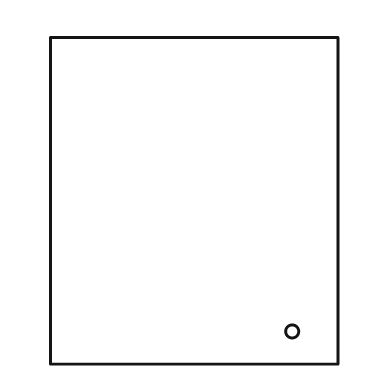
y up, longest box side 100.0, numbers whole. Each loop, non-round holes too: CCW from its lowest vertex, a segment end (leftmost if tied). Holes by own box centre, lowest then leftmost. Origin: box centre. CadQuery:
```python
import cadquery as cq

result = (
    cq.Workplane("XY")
    .moveTo(-44.0, -50.0)
    .lineTo(44.0, -50.0)
    .lineTo(44.0, 50.0)
    .lineTo(-44.0, 50.0)
    .close()
    .moveTo(30.0, -40.0)
    .circle(2.0)
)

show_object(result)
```